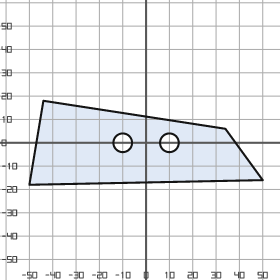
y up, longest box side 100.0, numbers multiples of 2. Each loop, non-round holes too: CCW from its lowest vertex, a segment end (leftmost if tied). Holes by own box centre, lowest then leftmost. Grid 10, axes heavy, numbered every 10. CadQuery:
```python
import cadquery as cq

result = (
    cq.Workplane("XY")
    .moveTo(-50.0, -18.0)
    .lineTo(50.0, -16.0)
    .lineTo(34.0, 6.0)
    .lineTo(-44.0, 18.0)
    .close()
    .moveTo(-10.0, 0.0)
    .circle(4.0)
    .moveTo(10.0, 0.0)
    .circle(4.0)
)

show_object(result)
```